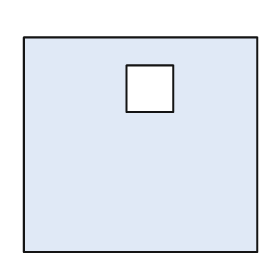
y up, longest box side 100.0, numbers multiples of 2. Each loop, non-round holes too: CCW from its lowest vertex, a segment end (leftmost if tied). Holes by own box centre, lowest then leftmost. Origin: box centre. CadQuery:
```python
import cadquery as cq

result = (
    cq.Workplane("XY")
    .moveTo(-50.0, -46.0)
    .lineTo(50.0, -46.0)
    .lineTo(50.0, 46.0)
    .lineTo(-50.0, 46.0)
    .close()
    .moveTo(-6.0, 14.0)
    .lineTo(14.0, 14.0)
    .lineTo(14.0, 34.0)
    .lineTo(-6.0, 34.0)
    .close()
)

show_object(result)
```